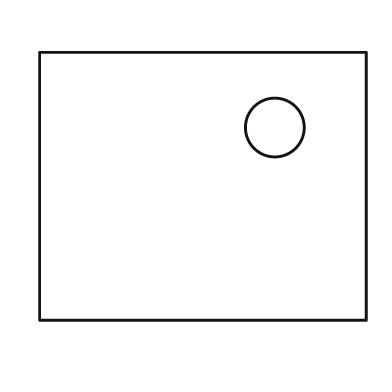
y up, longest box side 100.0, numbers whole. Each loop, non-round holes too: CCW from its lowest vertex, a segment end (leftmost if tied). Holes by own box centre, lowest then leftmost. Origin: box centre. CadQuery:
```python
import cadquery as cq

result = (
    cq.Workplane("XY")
    .moveTo(-50.0, -41.0)
    .lineTo(50.0, -41.0)
    .lineTo(50.0, 41.0)
    .lineTo(-50.0, 41.0)
    .close()
    .moveTo(22.0, 18.0)
    .circle(9.0)
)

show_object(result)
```